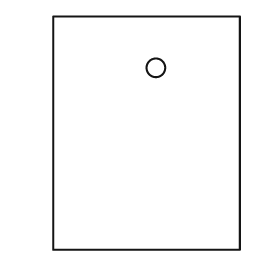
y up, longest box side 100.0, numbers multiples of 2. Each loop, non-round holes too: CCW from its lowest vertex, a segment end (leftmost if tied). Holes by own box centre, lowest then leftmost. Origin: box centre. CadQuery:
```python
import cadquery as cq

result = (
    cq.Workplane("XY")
    .moveTo(-40.0, -50.0)
    .lineTo(40.0, -50.0)
    .lineTo(40.0, 50.0)
    .lineTo(-40.0, 50.0)
    .close()
    .moveTo(4.0, 28.0)
    .circle(4.0)
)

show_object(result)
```